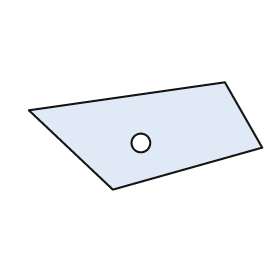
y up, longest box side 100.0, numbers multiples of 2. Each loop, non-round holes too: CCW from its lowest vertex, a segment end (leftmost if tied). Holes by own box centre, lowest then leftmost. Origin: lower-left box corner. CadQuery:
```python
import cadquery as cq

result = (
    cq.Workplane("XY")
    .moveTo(36.0, 0.0)
    .lineTo(100.0, 18.0)
    .lineTo(84.0, 46.0)
    .lineTo(0.0, 34.0)
    .close()
    .moveTo(48.0, 20.0)
    .circle(4.0)
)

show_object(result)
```